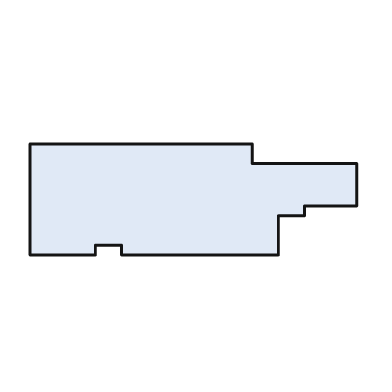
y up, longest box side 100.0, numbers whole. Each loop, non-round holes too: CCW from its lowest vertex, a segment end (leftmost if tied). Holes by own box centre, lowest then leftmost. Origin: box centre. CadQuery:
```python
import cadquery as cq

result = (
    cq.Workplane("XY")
    .moveTo(-50.0, -17.0)
    .lineTo(-30.0, -17.0)
    .lineTo(-30.0, -14.0)
    .lineTo(-22.0, -14.0)
    .lineTo(-22.0, -17.0)
    .lineTo(26.0, -17.0)
    .lineTo(26.0, -5.0)
    .lineTo(34.0, -5.0)
    .lineTo(34.0, -2.0)
    .lineTo(50.0, -2.0)
    .lineTo(50.0, 11.0)
    .lineTo(18.0, 11.0)
    .lineTo(18.0, 17.0)
    .lineTo(-50.0, 17.0)
    .close()
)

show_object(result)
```